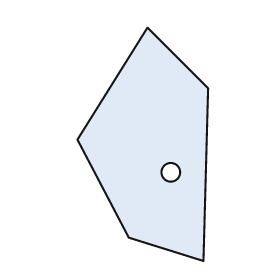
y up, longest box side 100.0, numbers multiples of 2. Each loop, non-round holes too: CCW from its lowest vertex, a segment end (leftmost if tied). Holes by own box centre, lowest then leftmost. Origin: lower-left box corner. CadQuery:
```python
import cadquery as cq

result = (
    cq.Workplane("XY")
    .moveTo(54.0, 0.0)
    .lineTo(56.0, 74.0)
    .lineTo(30.0, 100.0)
    .lineTo(0.0, 52.0)
    .lineTo(22.0, 10.0)
    .close()
    .moveTo(40.0, 38.0)
    .circle(4.0)
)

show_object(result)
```